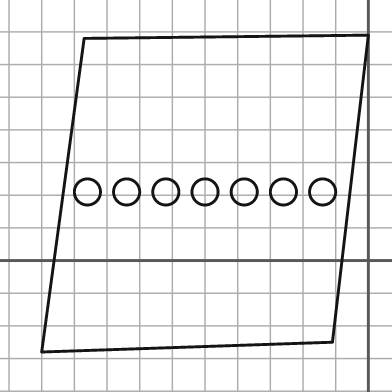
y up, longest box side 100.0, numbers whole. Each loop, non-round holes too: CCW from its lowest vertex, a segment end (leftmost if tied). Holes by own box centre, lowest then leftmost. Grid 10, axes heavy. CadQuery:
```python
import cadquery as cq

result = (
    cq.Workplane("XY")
    .moveTo(-100.0, -28.0)
    .lineTo(-11.0, -25.0)
    .lineTo(0.0, 69.0)
    .lineTo(-87.0, 68.0)
    .close()
    .moveTo(-86.0, 21.0)
    .circle(4.0)
    .moveTo(-74.0, 21.0)
    .circle(4.0)
    .moveTo(-62.0, 21.0)
    .circle(4.0)
    .moveTo(-50.0, 21.0)
    .circle(4.0)
    .moveTo(-38.0, 21.0)
    .circle(4.0)
    .moveTo(-26.0, 21.0)
    .circle(4.0)
    .moveTo(-14.0, 21.0)
    .circle(4.0)
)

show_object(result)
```